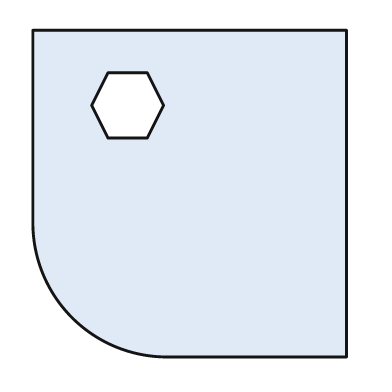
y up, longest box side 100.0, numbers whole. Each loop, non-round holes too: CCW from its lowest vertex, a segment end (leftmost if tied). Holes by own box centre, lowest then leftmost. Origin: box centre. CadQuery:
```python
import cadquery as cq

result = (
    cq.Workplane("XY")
    .moveTo(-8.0, -50.0)
    .lineTo(48.0, -50.0)
    .lineTo(48.0, 50.0)
    .lineTo(-48.0, 50.0)
    .lineTo(-48.0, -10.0)
    .threePointArc((-36.0, -38.0), (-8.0, -50.0))
    .close()
    .moveTo(-25.0, 17.0)
    .lineTo(-13.0, 17.0)
    .lineTo(-8.0, 27.0)
    .lineTo(-13.0, 37.0)
    .lineTo(-25.0, 37.0)
    .lineTo(-30.0, 27.0)
    .close()
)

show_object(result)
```